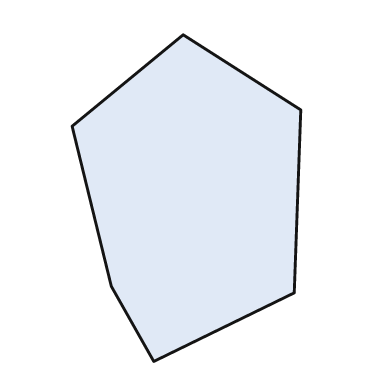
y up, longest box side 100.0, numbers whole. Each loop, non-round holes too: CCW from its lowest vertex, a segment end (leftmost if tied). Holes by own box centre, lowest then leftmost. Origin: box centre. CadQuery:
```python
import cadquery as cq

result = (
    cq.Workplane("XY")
    .moveTo(-10.0, -50.0)
    .lineTo(33.0, -29.0)
    .lineTo(35.0, 27.0)
    .lineTo(-1.0, 50.0)
    .lineTo(-35.0, 22.0)
    .lineTo(-23.0, -27.0)
    .close()
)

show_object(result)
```